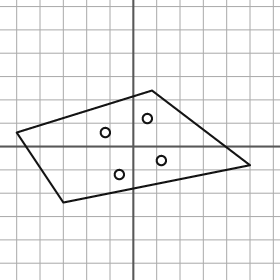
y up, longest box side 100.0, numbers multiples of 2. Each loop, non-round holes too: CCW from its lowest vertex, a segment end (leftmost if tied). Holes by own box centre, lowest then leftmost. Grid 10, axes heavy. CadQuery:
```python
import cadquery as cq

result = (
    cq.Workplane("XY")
    .moveTo(-30.0, -24.0)
    .lineTo(50.0, -8.0)
    .lineTo(8.0, 24.0)
    .lineTo(-50.0, 6.0)
    .close()
    .moveTo(-6.0, -12.0)
    .circle(2.0)
    .moveTo(12.0, -6.0)
    .circle(2.0)
    .moveTo(-12.0, 6.0)
    .circle(2.0)
    .moveTo(6.0, 12.0)
    .circle(2.0)
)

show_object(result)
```